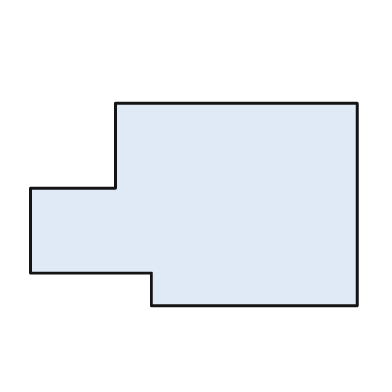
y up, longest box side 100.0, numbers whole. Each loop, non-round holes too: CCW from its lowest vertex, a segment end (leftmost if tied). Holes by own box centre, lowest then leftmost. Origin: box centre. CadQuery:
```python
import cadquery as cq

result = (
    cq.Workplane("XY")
    .moveTo(-13.0, -31.0)
    .lineTo(50.0, -31.0)
    .lineTo(50.0, 31.0)
    .lineTo(-24.0, 31.0)
    .lineTo(-24.0, 5.0)
    .lineTo(-50.0, 5.0)
    .lineTo(-50.0, -21.0)
    .lineTo(-13.0, -21.0)
    .close()
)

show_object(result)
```